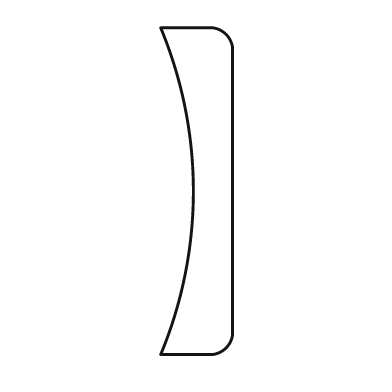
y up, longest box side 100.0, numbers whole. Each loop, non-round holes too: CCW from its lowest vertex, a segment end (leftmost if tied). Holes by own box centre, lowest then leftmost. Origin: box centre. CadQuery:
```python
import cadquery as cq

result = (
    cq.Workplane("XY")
    .moveTo(-11.0, -50.0)
    .lineTo(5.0, -50.0)
    .threePointArc((9.0, -48.0), (11.0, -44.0))
    .lineTo(11.0, 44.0)
    .threePointArc((9.0, 48.0), (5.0, 50.0))
    .lineTo(-11.0, 50.0)
    .threePointArc((-1.0, 0.0), (-11.0, -50.0))
    .close()
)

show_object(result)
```